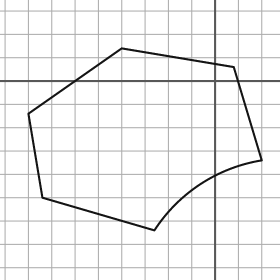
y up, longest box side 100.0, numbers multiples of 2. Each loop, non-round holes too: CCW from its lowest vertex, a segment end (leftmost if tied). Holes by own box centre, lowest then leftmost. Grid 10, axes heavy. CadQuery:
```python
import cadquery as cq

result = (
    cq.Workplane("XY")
    .moveTo(-26.0, -64.0)
    .threePointArc((-6.0, -44.0), (20.0, -34.0))
    .lineTo(8.0, 6.0)
    .lineTo(-40.0, 14.0)
    .lineTo(-80.0, -14.0)
    .lineTo(-74.0, -50.0)
    .close()
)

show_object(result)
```